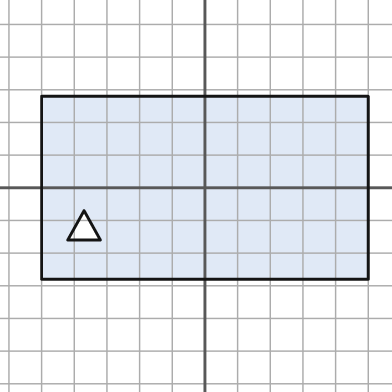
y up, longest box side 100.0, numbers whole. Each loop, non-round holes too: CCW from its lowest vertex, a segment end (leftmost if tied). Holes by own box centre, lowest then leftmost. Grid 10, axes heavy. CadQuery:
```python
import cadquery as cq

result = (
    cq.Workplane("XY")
    .moveTo(-50.0, -28.0)
    .lineTo(50.0, -28.0)
    .lineTo(50.0, 28.0)
    .lineTo(-50.0, 28.0)
    .close()
    .moveTo(-42.0, -16.0)
    .lineTo(-32.0, -16.0)
    .lineTo(-37.0, -7.0)
    .close()
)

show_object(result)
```